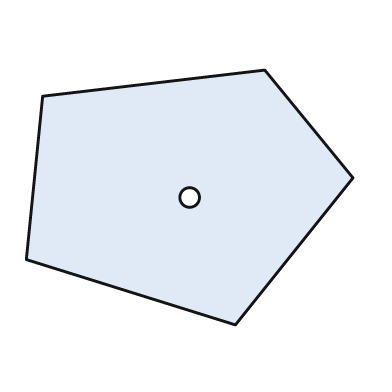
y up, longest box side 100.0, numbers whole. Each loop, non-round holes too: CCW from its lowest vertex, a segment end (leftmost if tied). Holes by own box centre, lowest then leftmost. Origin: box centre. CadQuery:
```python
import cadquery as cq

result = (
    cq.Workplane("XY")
    .moveTo(14.0, -39.0)
    .lineTo(50.0, 6.0)
    .lineTo(23.0, 39.0)
    .lineTo(-45.0, 31.0)
    .lineTo(-50.0, -19.0)
    .close()
    .moveTo(0.0, 0.0)
    .circle(3.0)
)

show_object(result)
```